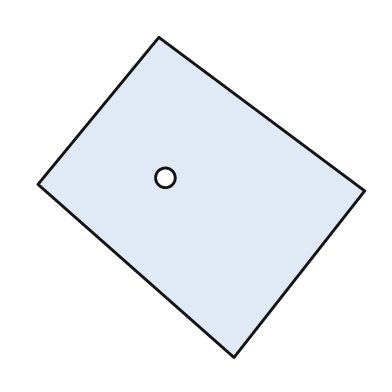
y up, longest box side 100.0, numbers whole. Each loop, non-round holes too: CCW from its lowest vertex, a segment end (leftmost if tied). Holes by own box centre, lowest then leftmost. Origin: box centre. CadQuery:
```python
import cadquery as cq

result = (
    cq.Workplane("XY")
    .moveTo(10.0, -49.0)
    .lineTo(50.0, 2.0)
    .lineTo(-13.0, 49.0)
    .lineTo(-50.0, 4.0)
    .close()
    .moveTo(-11.0, 6.0)
    .circle(3.0)
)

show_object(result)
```